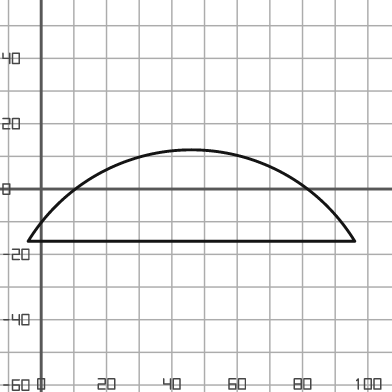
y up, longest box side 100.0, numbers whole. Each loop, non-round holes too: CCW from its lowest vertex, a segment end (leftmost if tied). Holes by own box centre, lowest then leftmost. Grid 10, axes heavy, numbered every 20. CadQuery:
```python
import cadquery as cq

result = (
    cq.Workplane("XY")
    .moveTo(-4.0, -16.0)
    .lineTo(96.0, -16.0)
    .threePointArc((46.0, 12.0), (-4.0, -16.0))
    .close()
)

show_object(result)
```